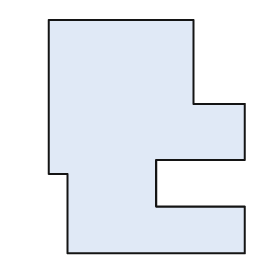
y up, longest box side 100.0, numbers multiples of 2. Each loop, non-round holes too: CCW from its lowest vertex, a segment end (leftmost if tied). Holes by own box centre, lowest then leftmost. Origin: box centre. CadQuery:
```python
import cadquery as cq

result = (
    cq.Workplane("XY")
    .moveTo(-34.0, -50.0)
    .lineTo(42.0, -50.0)
    .lineTo(42.0, -30.0)
    .lineTo(4.0, -30.0)
    .lineTo(4.0, -10.0)
    .lineTo(42.0, -10.0)
    .lineTo(42.0, 14.0)
    .lineTo(20.0, 14.0)
    .lineTo(20.0, 50.0)
    .lineTo(-42.0, 50.0)
    .lineTo(-42.0, -16.0)
    .lineTo(-34.0, -16.0)
    .close()
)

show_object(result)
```